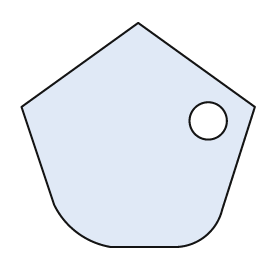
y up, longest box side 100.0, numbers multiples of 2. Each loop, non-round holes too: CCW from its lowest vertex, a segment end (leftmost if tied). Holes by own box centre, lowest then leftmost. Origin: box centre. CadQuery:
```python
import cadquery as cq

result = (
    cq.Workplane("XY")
    .moveTo(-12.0, -48.0)
    .lineTo(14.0, -48.0)
    .threePointArc((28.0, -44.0), (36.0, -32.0))
    .lineTo(50.0, 12.0)
    .lineTo(0.0, 48.0)
    .lineTo(-50.0, 12.0)
    .lineTo(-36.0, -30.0)
    .threePointArc((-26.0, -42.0), (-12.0, -48.0))
    .close()
    .moveTo(30.0, 6.0)
    .circle(8.0)
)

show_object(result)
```